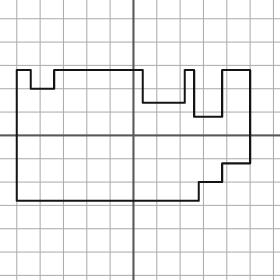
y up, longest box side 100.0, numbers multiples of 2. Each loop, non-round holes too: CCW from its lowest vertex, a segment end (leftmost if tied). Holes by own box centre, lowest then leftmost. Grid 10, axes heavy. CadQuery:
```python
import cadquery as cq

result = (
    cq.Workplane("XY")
    .moveTo(-50.0, -28.0)
    .lineTo(28.0, -28.0)
    .lineTo(28.0, -20.0)
    .lineTo(38.0, -20.0)
    .lineTo(38.0, -12.0)
    .lineTo(50.0, -12.0)
    .lineTo(50.0, 28.0)
    .lineTo(38.0, 28.0)
    .lineTo(38.0, 8.0)
    .lineTo(26.0, 8.0)
    .lineTo(26.0, 28.0)
    .lineTo(22.0, 28.0)
    .lineTo(22.0, 14.0)
    .lineTo(4.0, 14.0)
    .lineTo(4.0, 28.0)
    .lineTo(-34.0, 28.0)
    .lineTo(-34.0, 20.0)
    .lineTo(-44.0, 20.0)
    .lineTo(-44.0, 28.0)
    .lineTo(-50.0, 28.0)
    .close()
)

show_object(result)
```